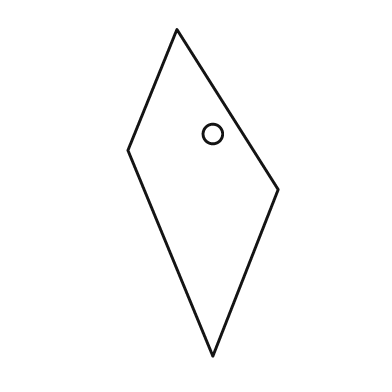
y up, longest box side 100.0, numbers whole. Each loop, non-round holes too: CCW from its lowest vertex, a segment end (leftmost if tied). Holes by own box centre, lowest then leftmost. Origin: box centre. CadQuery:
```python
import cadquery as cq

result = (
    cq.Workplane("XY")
    .moveTo(3.0, -50.0)
    .lineTo(23.0, 1.0)
    .lineTo(-8.0, 50.0)
    .lineTo(-23.0, 13.0)
    .close()
    .moveTo(3.0, 18.0)
    .circle(3.0)
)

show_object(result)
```